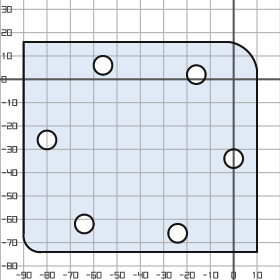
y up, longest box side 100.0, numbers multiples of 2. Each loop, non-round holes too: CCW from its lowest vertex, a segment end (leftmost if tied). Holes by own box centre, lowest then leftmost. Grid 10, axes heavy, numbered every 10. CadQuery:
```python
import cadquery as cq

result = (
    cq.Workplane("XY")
    .moveTo(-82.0, -74.0)
    .lineTo(10.0, -74.0)
    .lineTo(10.0, 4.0)
    .threePointArc((6.0, 12.0), (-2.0, 16.0))
    .lineTo(-90.0, 16.0)
    .lineTo(-90.0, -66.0)
    .threePointArc((-88.0, -72.0), (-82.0, -74.0))
    .close()
    .moveTo(-24.0, -66.0)
    .circle(4.0)
    .moveTo(-64.0, -62.0)
    .circle(4.0)
    .moveTo(0.0, -34.0)
    .circle(4.0)
    .moveTo(-80.0, -26.0)
    .circle(4.0)
    .moveTo(-16.0, 2.0)
    .circle(4.0)
    .moveTo(-56.0, 6.0)
    .circle(4.0)
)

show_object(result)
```